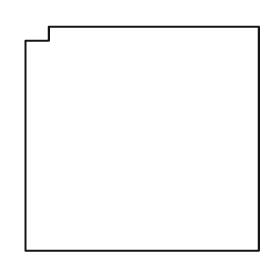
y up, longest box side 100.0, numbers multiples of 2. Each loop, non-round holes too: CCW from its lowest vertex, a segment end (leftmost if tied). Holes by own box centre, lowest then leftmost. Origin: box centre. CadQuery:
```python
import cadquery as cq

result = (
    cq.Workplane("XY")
    .moveTo(-50.0, -48.0)
    .lineTo(50.0, -48.0)
    .lineTo(50.0, 48.0)
    .lineTo(-40.0, 48.0)
    .lineTo(-40.0, 42.0)
    .lineTo(-50.0, 42.0)
    .close()
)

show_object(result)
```